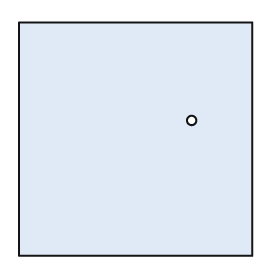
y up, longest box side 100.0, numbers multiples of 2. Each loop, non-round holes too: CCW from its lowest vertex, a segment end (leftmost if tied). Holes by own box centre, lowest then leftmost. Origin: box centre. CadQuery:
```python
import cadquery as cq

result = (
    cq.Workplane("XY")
    .moveTo(-50.0, -50.0)
    .lineTo(50.0, -50.0)
    .lineTo(50.0, 50.0)
    .lineTo(-50.0, 50.0)
    .close()
    .moveTo(24.0, 8.0)
    .circle(2.0)
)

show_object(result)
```